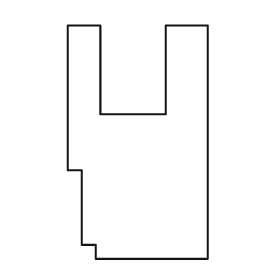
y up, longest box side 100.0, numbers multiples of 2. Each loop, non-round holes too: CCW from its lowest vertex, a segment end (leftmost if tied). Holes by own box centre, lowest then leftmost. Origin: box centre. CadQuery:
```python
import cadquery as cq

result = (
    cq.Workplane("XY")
    .moveTo(-18.0, -50.0)
    .lineTo(30.0, -50.0)
    .lineTo(30.0, 50.0)
    .lineTo(12.0, 50.0)
    .lineTo(12.0, 12.0)
    .lineTo(-16.0, 12.0)
    .lineTo(-16.0, 50.0)
    .lineTo(-30.0, 50.0)
    .lineTo(-30.0, -12.0)
    .lineTo(-24.0, -12.0)
    .lineTo(-24.0, -44.0)
    .lineTo(-18.0, -44.0)
    .close()
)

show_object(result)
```